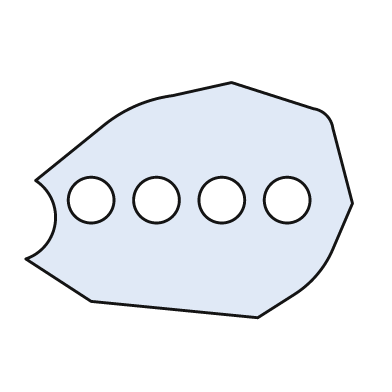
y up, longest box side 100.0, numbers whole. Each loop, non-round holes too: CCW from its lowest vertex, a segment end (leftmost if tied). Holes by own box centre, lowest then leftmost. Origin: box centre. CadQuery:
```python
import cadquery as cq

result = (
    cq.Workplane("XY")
    .moveTo(21.0, -36.0)
    .lineTo(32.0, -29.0)
    .threePointArc((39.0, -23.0), (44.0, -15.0))
    .lineTo(50.0, -1.0)
    .lineTo(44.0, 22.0)
    .threePointArc((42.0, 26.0), (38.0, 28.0))
    .lineTo(13.0, 36.0)
    .lineTo(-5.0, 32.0)
    .threePointArc((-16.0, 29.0), (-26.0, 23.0))
    .lineTo(-47.0, 6.0)
    .threePointArc((-41.0, -7.0), (-50.0, -18.0))
    .lineTo(-30.0, -31.0)
    .close()
    .moveTo(-30.0, 0.0)
    .circle(7.0)
    .moveTo(-10.0, 0.0)
    .circle(7.0)
    .moveTo(10.0, 0.0)
    .circle(7.0)
    .moveTo(30.0, 0.0)
    .circle(7.0)
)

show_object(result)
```